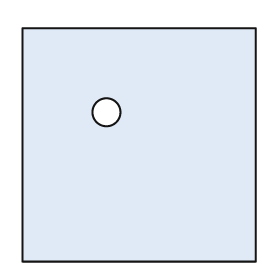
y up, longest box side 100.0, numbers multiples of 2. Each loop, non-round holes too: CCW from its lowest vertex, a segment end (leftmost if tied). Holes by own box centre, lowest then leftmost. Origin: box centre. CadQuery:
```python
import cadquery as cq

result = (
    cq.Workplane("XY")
    .moveTo(-50.0, -50.0)
    .lineTo(50.0, -50.0)
    .lineTo(50.0, 50.0)
    .lineTo(-50.0, 50.0)
    .close()
    .moveTo(-14.0, 14.0)
    .circle(6.0)
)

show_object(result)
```